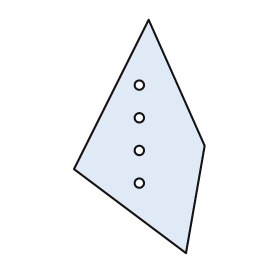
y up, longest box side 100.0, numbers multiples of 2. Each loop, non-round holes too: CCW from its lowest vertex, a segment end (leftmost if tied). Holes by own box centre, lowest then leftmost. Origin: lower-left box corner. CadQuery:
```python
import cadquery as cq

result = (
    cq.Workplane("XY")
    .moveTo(48.0, 0.0)
    .lineTo(56.0, 46.0)
    .lineTo(32.0, 100.0)
    .lineTo(0.0, 36.0)
    .close()
    .moveTo(28.0, 30.0)
    .circle(2.0)
    .moveTo(28.0, 44.0)
    .circle(2.0)
    .moveTo(28.0, 58.0)
    .circle(2.0)
    .moveTo(28.0, 72.0)
    .circle(2.0)
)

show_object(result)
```